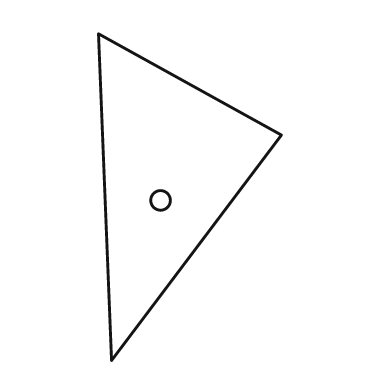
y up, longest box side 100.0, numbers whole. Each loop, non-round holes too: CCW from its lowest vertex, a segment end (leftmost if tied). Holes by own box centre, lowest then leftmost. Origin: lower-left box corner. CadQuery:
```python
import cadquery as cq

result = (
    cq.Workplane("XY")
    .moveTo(4.0, 0.0)
    .lineTo(56.0, 69.0)
    .lineTo(0.0, 100.0)
    .close()
    .moveTo(19.0, 49.0)
    .circle(3.0)
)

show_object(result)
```